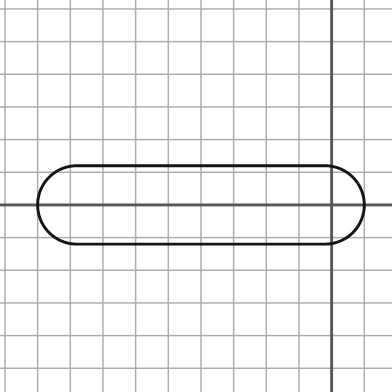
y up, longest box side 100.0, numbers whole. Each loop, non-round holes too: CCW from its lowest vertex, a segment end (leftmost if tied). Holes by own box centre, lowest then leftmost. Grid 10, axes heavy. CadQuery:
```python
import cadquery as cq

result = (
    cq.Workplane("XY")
    .moveTo(-78.0, -12.0)
    .lineTo(-2.0, -12.0)
    .threePointArc((10.0, 0.0), (-2.0, 12.0))
    .lineTo(-78.0, 12.0)
    .threePointArc((-90.0, 0.0), (-78.0, -12.0))
    .close()
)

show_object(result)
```